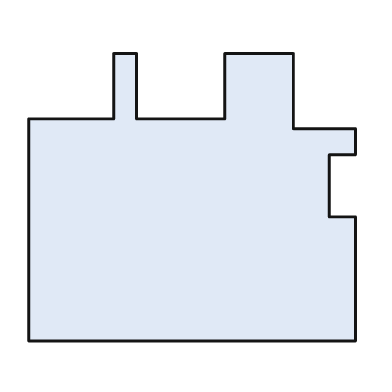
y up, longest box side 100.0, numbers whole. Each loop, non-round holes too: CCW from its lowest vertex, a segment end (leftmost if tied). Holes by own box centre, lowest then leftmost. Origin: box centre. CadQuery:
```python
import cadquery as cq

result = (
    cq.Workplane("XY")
    .moveTo(-50.0, -44.0)
    .lineTo(50.0, -44.0)
    .lineTo(50.0, -6.0)
    .lineTo(42.0, -6.0)
    .lineTo(42.0, 13.0)
    .lineTo(50.0, 13.0)
    .lineTo(50.0, 21.0)
    .lineTo(31.0, 21.0)
    .lineTo(31.0, 44.0)
    .lineTo(10.0, 44.0)
    .lineTo(10.0, 24.0)
    .lineTo(-17.0, 24.0)
    .lineTo(-17.0, 44.0)
    .lineTo(-24.0, 44.0)
    .lineTo(-24.0, 24.0)
    .lineTo(-50.0, 24.0)
    .close()
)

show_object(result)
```